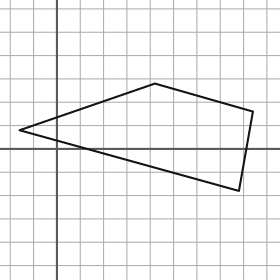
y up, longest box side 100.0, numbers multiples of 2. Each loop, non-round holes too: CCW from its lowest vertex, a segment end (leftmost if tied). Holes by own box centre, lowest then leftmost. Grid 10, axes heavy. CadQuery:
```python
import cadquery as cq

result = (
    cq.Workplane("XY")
    .moveTo(78.0, -18.0)
    .lineTo(84.0, 16.0)
    .lineTo(42.0, 28.0)
    .lineTo(-16.0, 8.0)
    .close()
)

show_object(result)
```